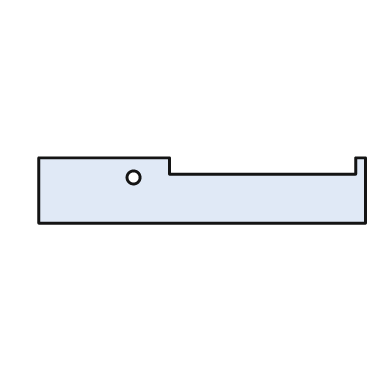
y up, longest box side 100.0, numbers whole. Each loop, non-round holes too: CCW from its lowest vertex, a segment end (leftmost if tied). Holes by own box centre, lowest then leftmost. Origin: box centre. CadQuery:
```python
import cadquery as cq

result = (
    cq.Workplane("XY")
    .moveTo(-50.0, -10.0)
    .lineTo(50.0, -10.0)
    .lineTo(50.0, 10.0)
    .lineTo(47.0, 10.0)
    .lineTo(47.0, 5.0)
    .lineTo(-10.0, 5.0)
    .lineTo(-10.0, 10.0)
    .lineTo(-50.0, 10.0)
    .close()
    .moveTo(-21.0, 4.0)
    .circle(2.0)
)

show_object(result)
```